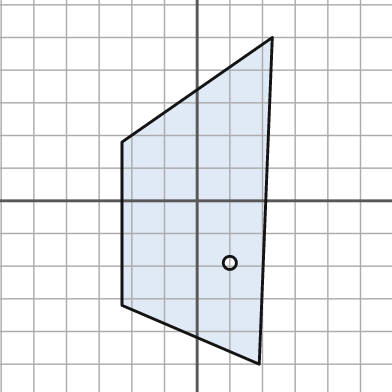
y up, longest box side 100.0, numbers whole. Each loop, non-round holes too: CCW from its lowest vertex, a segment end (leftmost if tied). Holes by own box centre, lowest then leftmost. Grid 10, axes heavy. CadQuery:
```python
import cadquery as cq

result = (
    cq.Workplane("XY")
    .moveTo(19.0, -50.0)
    .lineTo(23.0, 50.0)
    .lineTo(-23.0, 18.0)
    .lineTo(-23.0, -32.0)
    .close()
    .moveTo(10.0, -19.0)
    .circle(2.0)
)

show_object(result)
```